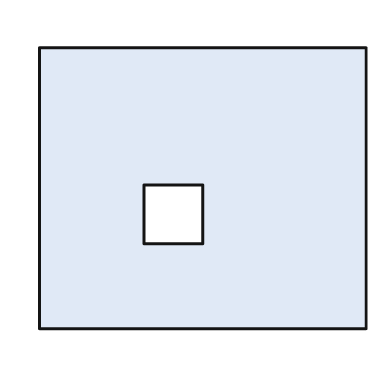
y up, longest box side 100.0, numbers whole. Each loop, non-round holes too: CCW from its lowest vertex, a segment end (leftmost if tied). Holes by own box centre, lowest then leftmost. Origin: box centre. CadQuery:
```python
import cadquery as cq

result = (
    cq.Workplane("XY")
    .moveTo(-50.0, -43.0)
    .lineTo(50.0, -43.0)
    .lineTo(50.0, 43.0)
    .lineTo(-50.0, 43.0)
    .close()
    .moveTo(-18.0, -17.0)
    .lineTo(0.0, -17.0)
    .lineTo(0.0, 1.0)
    .lineTo(-18.0, 1.0)
    .close()
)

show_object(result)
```